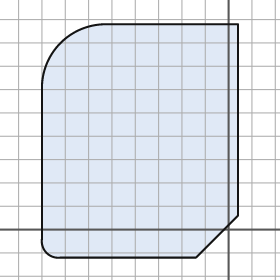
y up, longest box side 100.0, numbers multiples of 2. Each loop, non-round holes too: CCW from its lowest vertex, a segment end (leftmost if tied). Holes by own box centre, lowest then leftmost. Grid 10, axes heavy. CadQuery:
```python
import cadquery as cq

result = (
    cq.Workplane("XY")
    .moveTo(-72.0, -12.0)
    .lineTo(-14.0, -12.0)
    .lineTo(4.0, 6.0)
    .lineTo(4.0, 88.0)
    .lineTo(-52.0, 88.0)
    .threePointArc((-72.0, 80.0), (-80.0, 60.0))
    .lineTo(-80.0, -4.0)
    .threePointArc((-78.0, -10.0), (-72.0, -12.0))
    .close()
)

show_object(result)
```